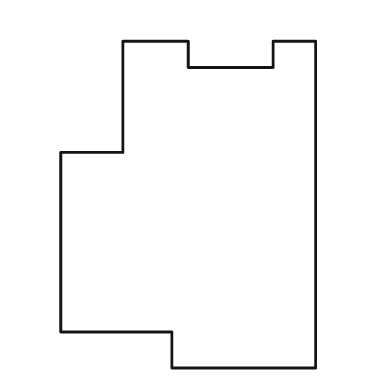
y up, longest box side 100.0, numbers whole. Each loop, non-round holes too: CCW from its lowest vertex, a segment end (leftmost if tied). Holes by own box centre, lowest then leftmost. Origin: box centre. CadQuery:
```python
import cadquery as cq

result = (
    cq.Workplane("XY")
    .moveTo(-5.0, -50.0)
    .lineTo(39.0, -50.0)
    .lineTo(39.0, 50.0)
    .lineTo(26.0, 50.0)
    .lineTo(26.0, 42.0)
    .lineTo(0.0, 42.0)
    .lineTo(0.0, 50.0)
    .lineTo(-20.0, 50.0)
    .lineTo(-20.0, 16.0)
    .lineTo(-39.0, 16.0)
    .lineTo(-39.0, -39.0)
    .lineTo(-5.0, -39.0)
    .close()
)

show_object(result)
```